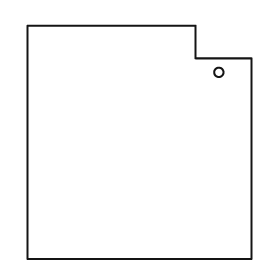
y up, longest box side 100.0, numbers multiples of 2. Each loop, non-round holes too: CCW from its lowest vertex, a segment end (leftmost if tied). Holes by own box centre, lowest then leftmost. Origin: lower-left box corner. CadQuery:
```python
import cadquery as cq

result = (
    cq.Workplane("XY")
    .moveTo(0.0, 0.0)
    .lineTo(96.0, 0.0)
    .lineTo(96.0, 86.0)
    .lineTo(72.0, 86.0)
    .lineTo(72.0, 100.0)
    .lineTo(0.0, 100.0)
    .close()
    .moveTo(82.0, 80.0)
    .circle(2.0)
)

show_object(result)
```